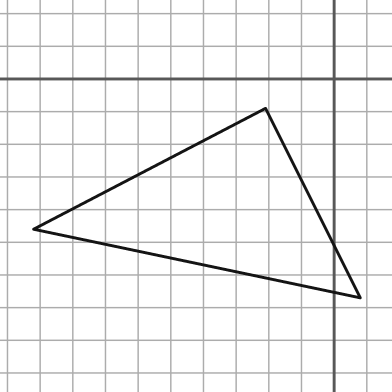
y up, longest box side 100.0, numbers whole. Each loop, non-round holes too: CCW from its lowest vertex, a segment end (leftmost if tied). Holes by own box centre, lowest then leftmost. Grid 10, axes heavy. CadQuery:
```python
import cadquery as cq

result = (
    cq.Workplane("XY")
    .moveTo(8.0, -67.0)
    .lineTo(-21.0, -9.0)
    .lineTo(-92.0, -46.0)
    .close()
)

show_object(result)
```